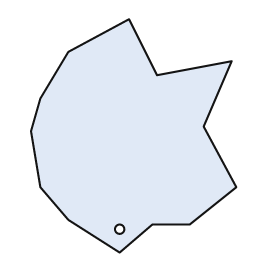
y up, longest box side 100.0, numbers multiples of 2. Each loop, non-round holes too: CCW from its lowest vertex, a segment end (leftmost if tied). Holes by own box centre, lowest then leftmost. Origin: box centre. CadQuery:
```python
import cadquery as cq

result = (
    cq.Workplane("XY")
    .moveTo(-6.0, -50.0)
    .lineTo(8.0, -38.0)
    .lineTo(24.0, -38.0)
    .lineTo(44.0, -22.0)
    .lineTo(30.0, 4.0)
    .lineTo(42.0, 32.0)
    .lineTo(10.0, 26.0)
    .lineTo(-2.0, 50.0)
    .lineTo(-28.0, 36.0)
    .lineTo(-40.0, 16.0)
    .lineTo(-44.0, 2.0)
    .lineTo(-40.0, -22.0)
    .lineTo(-28.0, -36.0)
    .close()
    .moveTo(-6.0, -40.0)
    .circle(2.0)
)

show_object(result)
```